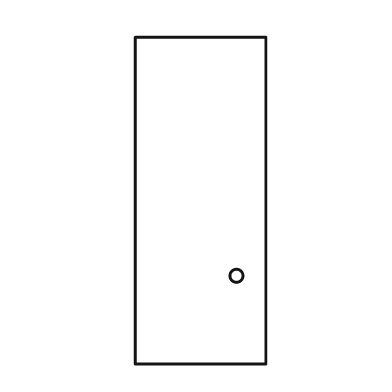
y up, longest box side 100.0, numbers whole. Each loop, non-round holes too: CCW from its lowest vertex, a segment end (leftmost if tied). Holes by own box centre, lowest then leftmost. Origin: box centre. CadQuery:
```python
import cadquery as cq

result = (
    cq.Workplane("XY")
    .moveTo(-20.0, -50.0)
    .lineTo(20.0, -50.0)
    .lineTo(20.0, 50.0)
    .lineTo(-20.0, 50.0)
    .close()
    .moveTo(11.0, -23.0)
    .circle(2.0)
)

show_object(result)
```